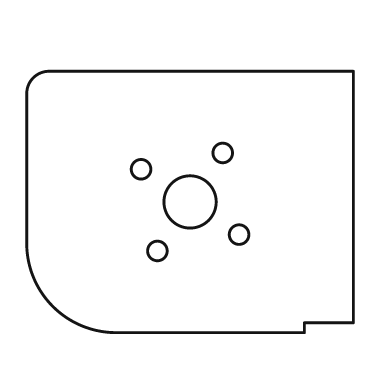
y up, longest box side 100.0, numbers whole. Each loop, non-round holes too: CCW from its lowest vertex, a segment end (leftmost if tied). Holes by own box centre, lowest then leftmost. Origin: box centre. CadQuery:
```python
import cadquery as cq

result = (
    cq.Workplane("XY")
    .moveTo(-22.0, -40.0)
    .lineTo(35.0, -40.0)
    .lineTo(35.0, -37.0)
    .lineTo(50.0, -37.0)
    .lineTo(50.0, 40.0)
    .lineTo(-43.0, 40.0)
    .threePointArc((-48.0, 38.0), (-50.0, 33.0))
    .lineTo(-50.0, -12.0)
    .threePointArc((-42.0, -32.0), (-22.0, -40.0))
    .close()
    .moveTo(-10.0, -15.0)
    .circle(3.0)
    .moveTo(15.0, -10.0)
    .circle(3.0)
    .moveTo(0.0, 0.0)
    .circle(8.0)
    .moveTo(-15.0, 10.0)
    .circle(3.0)
    .moveTo(10.0, 15.0)
    .circle(3.0)
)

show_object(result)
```